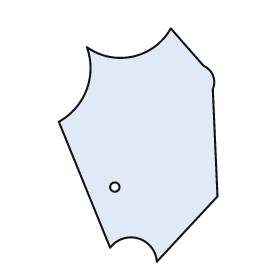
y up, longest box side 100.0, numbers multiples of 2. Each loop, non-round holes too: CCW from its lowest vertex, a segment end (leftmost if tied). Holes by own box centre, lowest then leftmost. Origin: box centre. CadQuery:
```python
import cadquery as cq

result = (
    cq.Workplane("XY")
    .moveTo(8.0, -50.0)
    .lineTo(34.0, -22.0)
    .lineTo(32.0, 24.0)
    .threePointArc((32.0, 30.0), (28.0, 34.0))
    .lineTo(14.0, 50.0)
    .threePointArc((-2.0, 38.0), (-22.0, 42.0))
    .threePointArc((-22.0, 24.0), (-34.0, 10.0))
    .lineTo(-12.0, -44.0)
    .threePointArc((0.0, -40.0), (8.0, -50.0))
    .close()
    .moveTo(-10.0, -18.0)
    .circle(2.0)
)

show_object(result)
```